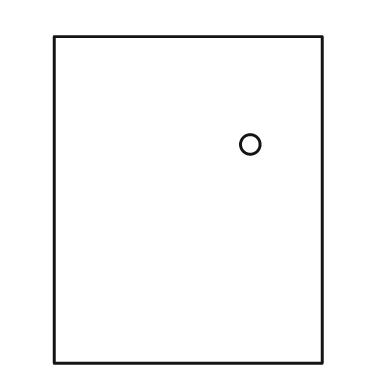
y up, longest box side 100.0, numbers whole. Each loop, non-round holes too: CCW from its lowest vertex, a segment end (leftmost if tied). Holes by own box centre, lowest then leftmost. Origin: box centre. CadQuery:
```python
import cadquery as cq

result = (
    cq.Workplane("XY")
    .moveTo(-41.0, -50.0)
    .lineTo(41.0, -50.0)
    .lineTo(41.0, 50.0)
    .lineTo(-41.0, 50.0)
    .close()
    .moveTo(19.0, 17.0)
    .circle(3.0)
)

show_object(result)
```